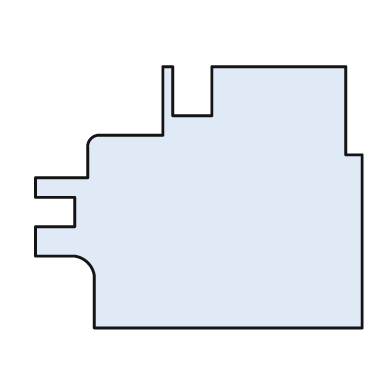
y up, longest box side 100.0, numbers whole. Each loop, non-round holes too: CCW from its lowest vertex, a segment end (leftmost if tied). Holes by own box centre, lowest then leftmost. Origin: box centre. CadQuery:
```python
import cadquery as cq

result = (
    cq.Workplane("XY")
    .moveTo(-32.0, -40.0)
    .lineTo(50.0, -40.0)
    .lineTo(50.0, 13.0)
    .lineTo(45.0, 13.0)
    .lineTo(45.0, 40.0)
    .lineTo(4.0, 40.0)
    .lineTo(4.0, 25.0)
    .lineTo(-8.0, 25.0)
    .lineTo(-8.0, 40.0)
    .lineTo(-11.0, 40.0)
    .lineTo(-11.0, 19.0)
    .lineTo(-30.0, 19.0)
    .threePointArc((-33.0, 18.0), (-34.0, 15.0))
    .lineTo(-34.0, 6.0)
    .lineTo(-50.0, 6.0)
    .lineTo(-50.0, 0.0)
    .lineTo(-38.0, 0.0)
    .lineTo(-38.0, -9.0)
    .lineTo(-50.0, -9.0)
    .lineTo(-50.0, -18.0)
    .lineTo(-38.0, -18.0)
    .threePointArc((-34.0, -20.0), (-32.0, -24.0))
    .close()
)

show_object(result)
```